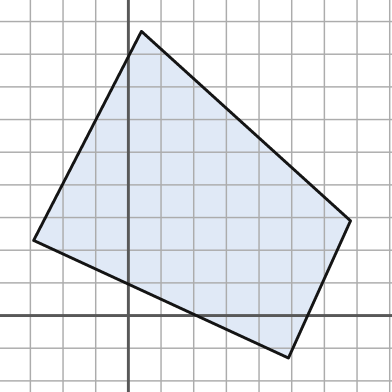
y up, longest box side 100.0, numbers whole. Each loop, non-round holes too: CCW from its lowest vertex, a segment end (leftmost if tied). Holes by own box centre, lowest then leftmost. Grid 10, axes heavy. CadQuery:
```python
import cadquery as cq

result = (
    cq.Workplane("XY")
    .moveTo(49.0, -13.0)
    .lineTo(68.0, 29.0)
    .lineTo(4.0, 87.0)
    .lineTo(-29.0, 23.0)
    .close()
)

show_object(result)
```